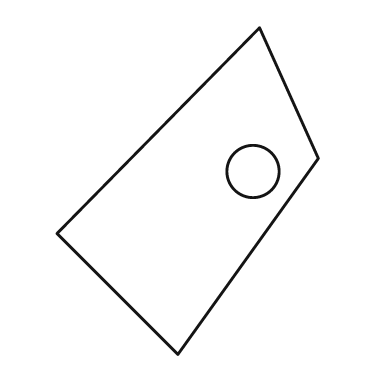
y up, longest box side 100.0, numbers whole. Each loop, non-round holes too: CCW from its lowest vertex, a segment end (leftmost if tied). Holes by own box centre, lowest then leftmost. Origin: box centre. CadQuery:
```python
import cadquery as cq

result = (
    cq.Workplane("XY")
    .moveTo(-3.0, -50.0)
    .lineTo(40.0, 10.0)
    .lineTo(22.0, 50.0)
    .lineTo(-40.0, -13.0)
    .close()
    .moveTo(20.0, 6.0)
    .circle(8.0)
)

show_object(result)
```